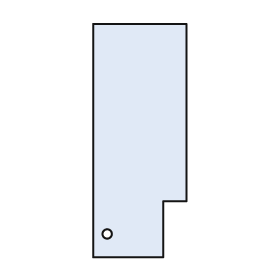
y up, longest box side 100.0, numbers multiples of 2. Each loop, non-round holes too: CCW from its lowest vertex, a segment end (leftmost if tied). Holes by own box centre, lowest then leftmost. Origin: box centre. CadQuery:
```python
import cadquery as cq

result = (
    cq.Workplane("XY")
    .moveTo(-20.0, -50.0)
    .lineTo(10.0, -50.0)
    .lineTo(10.0, -26.0)
    .lineTo(20.0, -26.0)
    .lineTo(20.0, 50.0)
    .lineTo(-20.0, 50.0)
    .close()
    .moveTo(-14.0, -40.0)
    .circle(2.0)
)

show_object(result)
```